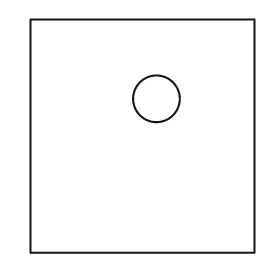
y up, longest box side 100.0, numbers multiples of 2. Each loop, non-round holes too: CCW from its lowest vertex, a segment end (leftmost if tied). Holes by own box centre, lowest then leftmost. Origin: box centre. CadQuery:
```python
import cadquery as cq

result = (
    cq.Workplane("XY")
    .moveTo(-48.0, -50.0)
    .lineTo(48.0, -50.0)
    .lineTo(48.0, 50.0)
    .lineTo(-48.0, 50.0)
    .close()
    .moveTo(6.0, 16.0)
    .circle(10.0)
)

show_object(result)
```